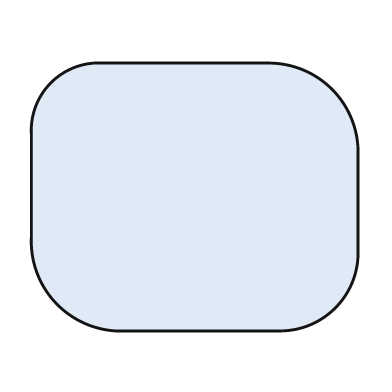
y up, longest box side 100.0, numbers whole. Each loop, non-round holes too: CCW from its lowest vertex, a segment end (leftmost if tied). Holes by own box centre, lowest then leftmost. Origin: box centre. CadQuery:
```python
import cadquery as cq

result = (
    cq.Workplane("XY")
    .moveTo(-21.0, -41.0)
    .lineTo(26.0, -41.0)
    .threePointArc((43.0, -34.0), (50.0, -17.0))
    .lineTo(50.0, 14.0)
    .threePointArc((42.0, 33.0), (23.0, 41.0))
    .lineTo(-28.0, 41.0)
    .threePointArc((-44.0, 35.0), (-50.0, 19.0))
    .lineTo(-50.0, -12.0)
    .threePointArc((-42.0, -33.0), (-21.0, -41.0))
    .close()
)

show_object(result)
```